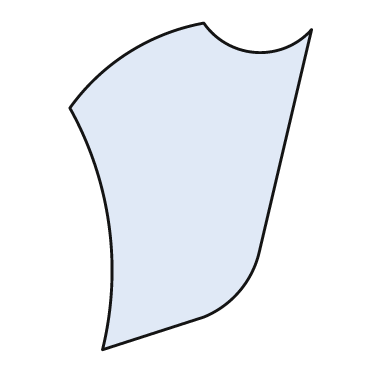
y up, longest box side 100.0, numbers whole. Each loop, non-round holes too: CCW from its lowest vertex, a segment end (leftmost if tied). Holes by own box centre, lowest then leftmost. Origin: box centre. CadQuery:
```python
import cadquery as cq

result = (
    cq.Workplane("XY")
    .moveTo(-27.0, -50.0)
    .lineTo(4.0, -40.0)
    .threePointArc((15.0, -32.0), (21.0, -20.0))
    .lineTo(37.0, 48.0)
    .threePointArc((20.0, 41.0), (4.0, 50.0))
    .threePointArc((-19.0, 41.0), (-37.0, 24.0))
    .threePointArc((-25.0, -12.0), (-27.0, -50.0))
    .close()
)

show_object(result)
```